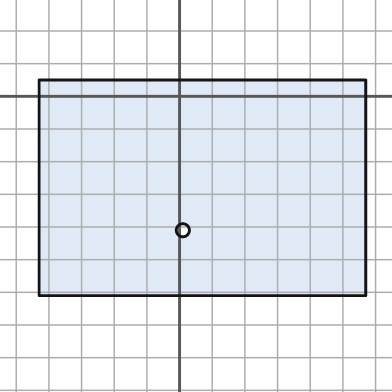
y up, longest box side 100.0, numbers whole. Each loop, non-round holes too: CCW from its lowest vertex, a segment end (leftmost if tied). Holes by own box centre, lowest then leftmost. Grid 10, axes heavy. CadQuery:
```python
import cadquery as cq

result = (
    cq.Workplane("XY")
    .moveTo(-43.0, -61.0)
    .lineTo(57.0, -61.0)
    .lineTo(57.0, 5.0)
    .lineTo(-43.0, 5.0)
    .close()
    .moveTo(1.0, -41.0)
    .circle(2.0)
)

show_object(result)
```